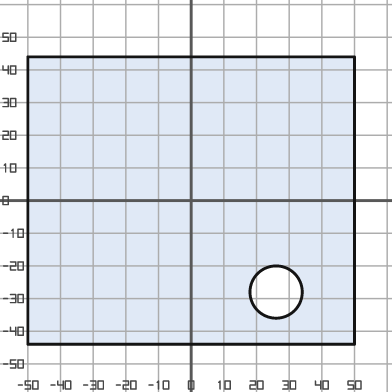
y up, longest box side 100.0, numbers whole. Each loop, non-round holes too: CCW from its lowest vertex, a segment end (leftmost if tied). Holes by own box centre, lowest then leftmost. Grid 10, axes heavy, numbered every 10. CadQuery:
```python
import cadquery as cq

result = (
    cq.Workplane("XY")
    .moveTo(-50.0, -44.0)
    .lineTo(50.0, -44.0)
    .lineTo(50.0, 44.0)
    .lineTo(-50.0, 44.0)
    .close()
    .moveTo(26.0, -28.0)
    .circle(8.0)
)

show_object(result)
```